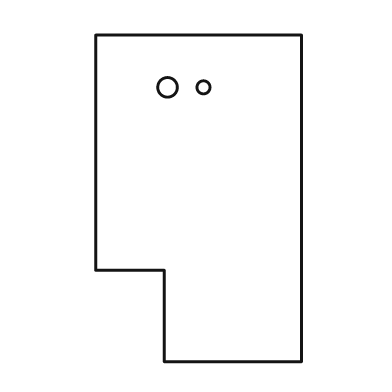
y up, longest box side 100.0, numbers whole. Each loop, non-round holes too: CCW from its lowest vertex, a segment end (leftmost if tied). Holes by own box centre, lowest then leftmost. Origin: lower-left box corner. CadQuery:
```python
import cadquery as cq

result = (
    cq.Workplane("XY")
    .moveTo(21.0, 0.0)
    .lineTo(63.0, 0.0)
    .lineTo(63.0, 100.0)
    .lineTo(0.0, 100.0)
    .lineTo(0.0, 28.0)
    .lineTo(21.0, 28.0)
    .close()
    .moveTo(22.0, 84.0)
    .circle(3.0)
    .moveTo(33.0, 84.0)
    .circle(2.0)
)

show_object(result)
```